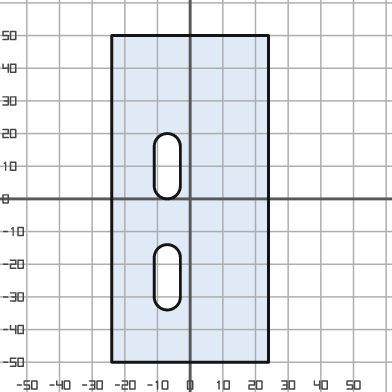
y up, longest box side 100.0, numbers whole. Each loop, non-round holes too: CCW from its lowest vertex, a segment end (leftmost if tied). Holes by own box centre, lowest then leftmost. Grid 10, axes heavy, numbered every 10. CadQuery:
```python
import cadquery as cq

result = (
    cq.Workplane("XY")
    .moveTo(-24.0, -50.0)
    .lineTo(24.0, -50.0)
    .lineTo(24.0, 50.0)
    .lineTo(-24.0, 50.0)
    .close()
    .moveTo(-11.0, -30.0)
    .threePointArc((-7.0, -34.0), (-3.0, -30.0))
    .lineTo(-3.0, -18.0)
    .threePointArc((-7.0, -14.0), (-11.0, -18.0))
    .close()
    .moveTo(-11.0, 4.0)
    .threePointArc((-7.0, 0.0), (-3.0, 4.0))
    .lineTo(-3.0, 16.0)
    .threePointArc((-7.0, 20.0), (-11.0, 16.0))
    .close()
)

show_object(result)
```